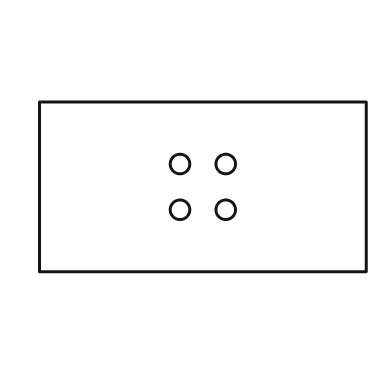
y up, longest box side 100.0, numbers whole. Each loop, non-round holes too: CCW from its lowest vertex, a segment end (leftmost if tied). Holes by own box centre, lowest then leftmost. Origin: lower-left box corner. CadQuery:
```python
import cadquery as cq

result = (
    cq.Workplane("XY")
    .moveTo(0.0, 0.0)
    .lineTo(100.0, 0.0)
    .lineTo(100.0, 52.0)
    .lineTo(0.0, 52.0)
    .close()
    .moveTo(43.0, 19.0)
    .circle(3.0)
    .moveTo(57.0, 19.0)
    .circle(3.0)
    .moveTo(43.0, 33.0)
    .circle(3.0)
    .moveTo(57.0, 33.0)
    .circle(3.0)
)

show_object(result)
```